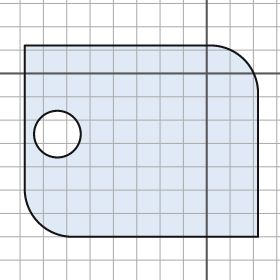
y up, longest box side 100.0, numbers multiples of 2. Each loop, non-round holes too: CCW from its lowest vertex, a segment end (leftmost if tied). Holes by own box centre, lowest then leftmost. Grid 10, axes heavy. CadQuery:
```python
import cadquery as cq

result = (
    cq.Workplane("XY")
    .moveTo(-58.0, -70.0)
    .lineTo(22.0, -70.0)
    .lineTo(22.0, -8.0)
    .threePointArc((16.0, 6.0), (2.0, 12.0))
    .lineTo(-78.0, 12.0)
    .lineTo(-78.0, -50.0)
    .threePointArc((-72.0, -64.0), (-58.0, -70.0))
    .close()
    .moveTo(-64.0, -26.0)
    .circle(10.0)
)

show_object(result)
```